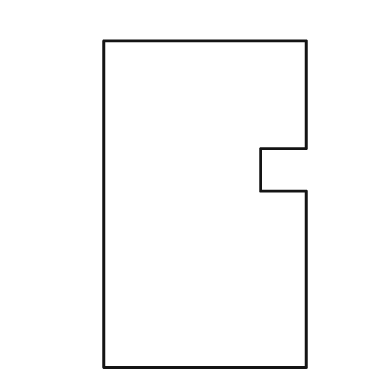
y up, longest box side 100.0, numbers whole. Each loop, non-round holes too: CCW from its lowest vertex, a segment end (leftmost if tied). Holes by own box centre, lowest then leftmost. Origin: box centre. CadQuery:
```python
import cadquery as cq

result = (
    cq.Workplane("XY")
    .moveTo(-31.0, -50.0)
    .lineTo(31.0, -50.0)
    .lineTo(31.0, 4.0)
    .lineTo(17.0, 4.0)
    .lineTo(17.0, 17.0)
    .lineTo(31.0, 17.0)
    .lineTo(31.0, 50.0)
    .lineTo(-31.0, 50.0)
    .close()
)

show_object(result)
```